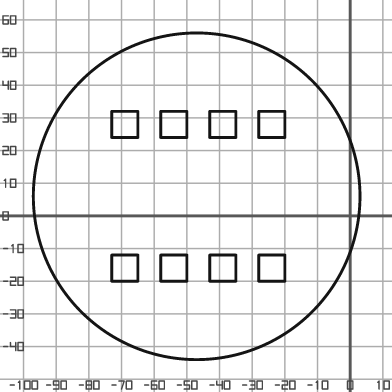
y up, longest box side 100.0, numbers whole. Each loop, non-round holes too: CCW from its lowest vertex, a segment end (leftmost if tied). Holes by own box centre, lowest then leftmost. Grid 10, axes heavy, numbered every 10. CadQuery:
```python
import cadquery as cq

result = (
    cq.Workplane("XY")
    .moveTo(-47.0, 6.0)
    .circle(50.0)
    .moveTo(-73.0, -20.0)
    .lineTo(-65.0, -20.0)
    .lineTo(-65.0, -12.0)
    .lineTo(-73.0, -12.0)
    .close()
    .moveTo(-58.0, -20.0)
    .lineTo(-50.0, -20.0)
    .lineTo(-50.0, -12.0)
    .lineTo(-58.0, -12.0)
    .close()
    .moveTo(-43.0, -20.0)
    .lineTo(-35.0, -20.0)
    .lineTo(-35.0, -12.0)
    .lineTo(-43.0, -12.0)
    .close()
    .moveTo(-28.0, -20.0)
    .lineTo(-20.0, -20.0)
    .lineTo(-20.0, -12.0)
    .lineTo(-28.0, -12.0)
    .close()
    .moveTo(-73.0, 24.0)
    .lineTo(-65.0, 24.0)
    .lineTo(-65.0, 32.0)
    .lineTo(-73.0, 32.0)
    .close()
    .moveTo(-58.0, 24.0)
    .lineTo(-50.0, 24.0)
    .lineTo(-50.0, 32.0)
    .lineTo(-58.0, 32.0)
    .close()
    .moveTo(-43.0, 24.0)
    .lineTo(-35.0, 24.0)
    .lineTo(-35.0, 32.0)
    .lineTo(-43.0, 32.0)
    .close()
    .moveTo(-28.0, 24.0)
    .lineTo(-20.0, 24.0)
    .lineTo(-20.0, 32.0)
    .lineTo(-28.0, 32.0)
    .close()
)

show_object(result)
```